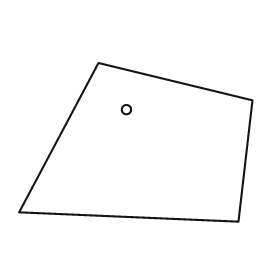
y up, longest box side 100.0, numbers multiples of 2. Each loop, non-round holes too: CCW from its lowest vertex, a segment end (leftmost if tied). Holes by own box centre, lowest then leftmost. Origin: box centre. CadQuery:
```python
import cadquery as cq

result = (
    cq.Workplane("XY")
    .moveTo(44.0, -34.0)
    .lineTo(50.0, 18.0)
    .lineTo(-16.0, 34.0)
    .lineTo(-50.0, -30.0)
    .close()
    .moveTo(-4.0, 14.0)
    .circle(2.0)
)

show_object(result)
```